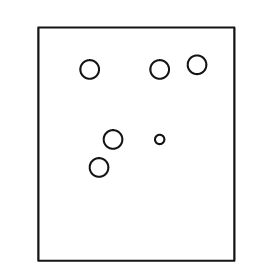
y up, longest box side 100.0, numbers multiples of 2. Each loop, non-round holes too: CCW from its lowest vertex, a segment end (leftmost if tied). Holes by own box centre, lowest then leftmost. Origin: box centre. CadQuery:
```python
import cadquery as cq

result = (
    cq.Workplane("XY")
    .moveTo(-42.0, -50.0)
    .lineTo(42.0, -50.0)
    .lineTo(42.0, 50.0)
    .lineTo(-42.0, 50.0)
    .close()
    .moveTo(-16.0, -10.0)
    .circle(4.0)
    .moveTo(-10.0, 2.0)
    .circle(4.0)
    .moveTo(10.0, 2.0)
    .circle(2.0)
    .moveTo(-20.0, 32.0)
    .circle(4.0)
    .moveTo(10.0, 32.0)
    .circle(4.0)
    .moveTo(26.0, 34.0)
    .circle(4.0)
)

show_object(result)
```